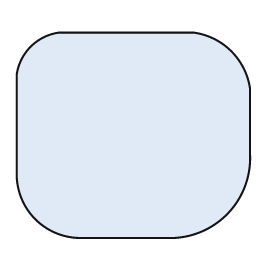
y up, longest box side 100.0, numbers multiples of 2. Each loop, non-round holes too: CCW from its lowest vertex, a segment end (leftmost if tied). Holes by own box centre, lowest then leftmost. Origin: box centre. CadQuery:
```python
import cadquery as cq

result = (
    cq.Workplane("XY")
    .moveTo(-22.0, -44.0)
    .lineTo(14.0, -44.0)
    .threePointArc((40.0, -34.0), (50.0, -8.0))
    .lineTo(50.0, 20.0)
    .threePointArc((42.0, 36.0), (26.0, 44.0))
    .lineTo(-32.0, 44.0)
    .threePointArc((-44.0, 38.0), (-50.0, 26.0))
    .lineTo(-50.0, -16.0)
    .threePointArc((-42.0, -36.0), (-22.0, -44.0))
    .close()
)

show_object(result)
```